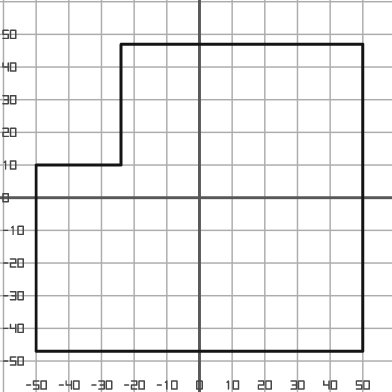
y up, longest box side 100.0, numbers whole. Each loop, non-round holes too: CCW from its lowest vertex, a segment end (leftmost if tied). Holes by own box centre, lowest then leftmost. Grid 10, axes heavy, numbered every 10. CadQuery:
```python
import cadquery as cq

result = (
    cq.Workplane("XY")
    .moveTo(-50.0, -47.0)
    .lineTo(50.0, -47.0)
    .lineTo(50.0, 47.0)
    .lineTo(-24.0, 47.0)
    .lineTo(-24.0, 10.0)
    .lineTo(-50.0, 10.0)
    .close()
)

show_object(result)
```